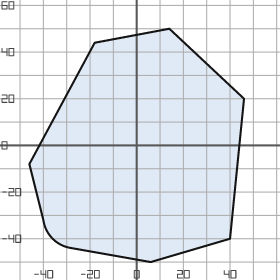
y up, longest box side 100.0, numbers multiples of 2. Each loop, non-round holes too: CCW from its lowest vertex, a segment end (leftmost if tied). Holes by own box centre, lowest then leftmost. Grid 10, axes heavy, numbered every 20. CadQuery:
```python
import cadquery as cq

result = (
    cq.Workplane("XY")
    .moveTo(6.0, -50.0)
    .lineTo(40.0, -40.0)
    .lineTo(46.0, 20.0)
    .lineTo(14.0, 50.0)
    .lineTo(-18.0, 44.0)
    .lineTo(-46.0, -8.0)
    .lineTo(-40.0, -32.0)
    .threePointArc((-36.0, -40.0), (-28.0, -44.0))
    .close()
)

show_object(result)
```